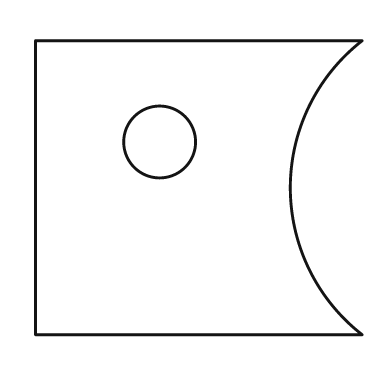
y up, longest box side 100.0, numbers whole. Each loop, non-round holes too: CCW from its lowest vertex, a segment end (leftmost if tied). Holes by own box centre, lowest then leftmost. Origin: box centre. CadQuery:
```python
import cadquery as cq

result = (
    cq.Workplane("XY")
    .moveTo(-50.0, -45.0)
    .lineTo(50.0, -45.0)
    .threePointArc((28.0, 0.0), (50.0, 45.0))
    .lineTo(-50.0, 45.0)
    .close()
    .moveTo(-12.0, 14.0)
    .circle(11.0)
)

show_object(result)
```